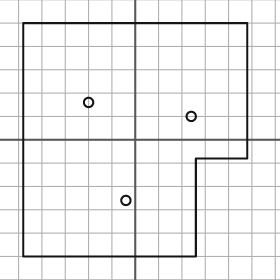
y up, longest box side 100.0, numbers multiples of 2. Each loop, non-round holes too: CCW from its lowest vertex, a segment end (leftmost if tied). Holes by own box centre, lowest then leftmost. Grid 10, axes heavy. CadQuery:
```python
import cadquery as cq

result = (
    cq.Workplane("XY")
    .moveTo(-48.0, -50.0)
    .lineTo(26.0, -50.0)
    .lineTo(26.0, -8.0)
    .lineTo(48.0, -8.0)
    .lineTo(48.0, 50.0)
    .lineTo(-48.0, 50.0)
    .close()
    .moveTo(-4.0, -26.0)
    .circle(2.0)
    .moveTo(24.0, 10.0)
    .circle(2.0)
    .moveTo(-20.0, 16.0)
    .circle(2.0)
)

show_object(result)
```